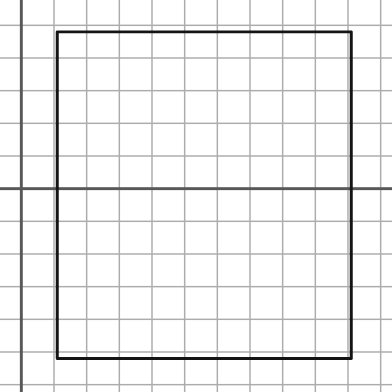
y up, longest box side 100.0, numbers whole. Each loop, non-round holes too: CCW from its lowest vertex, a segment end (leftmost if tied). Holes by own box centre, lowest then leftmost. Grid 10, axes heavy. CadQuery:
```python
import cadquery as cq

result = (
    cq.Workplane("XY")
    .moveTo(11.0, -52.0)
    .lineTo(101.0, -52.0)
    .lineTo(101.0, 48.0)
    .lineTo(11.0, 48.0)
    .close()
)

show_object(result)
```